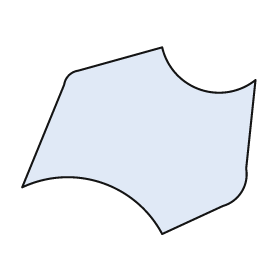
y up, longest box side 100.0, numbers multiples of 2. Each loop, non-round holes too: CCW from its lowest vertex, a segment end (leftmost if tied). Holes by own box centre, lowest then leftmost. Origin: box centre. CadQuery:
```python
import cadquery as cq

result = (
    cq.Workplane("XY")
    .moveTo(10.0, -40.0)
    .lineTo(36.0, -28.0)
    .threePointArc((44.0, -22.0), (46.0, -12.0))
    .lineTo(50.0, 26.0)
    .threePointArc((26.0, 22.0), (10.0, 40.0))
    .lineTo(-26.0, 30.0)
    .threePointArc((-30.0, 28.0), (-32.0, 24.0))
    .lineTo(-50.0, -20.0)
    .threePointArc((-16.0, -18.0), (10.0, -40.0))
    .close()
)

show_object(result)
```